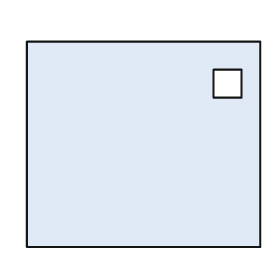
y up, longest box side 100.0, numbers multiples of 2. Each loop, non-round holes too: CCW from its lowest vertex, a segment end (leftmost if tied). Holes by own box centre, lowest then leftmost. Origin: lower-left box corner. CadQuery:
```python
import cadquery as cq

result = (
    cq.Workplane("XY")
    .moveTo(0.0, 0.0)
    .lineTo(100.0, 0.0)
    .lineTo(100.0, 88.0)
    .lineTo(0.0, 88.0)
    .close()
    .moveTo(80.0, 64.0)
    .lineTo(92.0, 64.0)
    .lineTo(92.0, 76.0)
    .lineTo(80.0, 76.0)
    .close()
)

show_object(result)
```